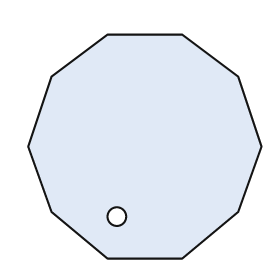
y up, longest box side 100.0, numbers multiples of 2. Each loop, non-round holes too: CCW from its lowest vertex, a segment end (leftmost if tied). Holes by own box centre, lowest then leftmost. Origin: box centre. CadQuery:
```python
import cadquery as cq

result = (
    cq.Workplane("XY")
    .moveTo(-16.0, -48.0)
    .lineTo(16.0, -48.0)
    .lineTo(40.0, -28.0)
    .lineTo(50.0, 0.0)
    .lineTo(40.0, 30.0)
    .lineTo(16.0, 48.0)
    .lineTo(-16.0, 48.0)
    .lineTo(-40.0, 30.0)
    .lineTo(-50.0, 0.0)
    .lineTo(-40.0, -28.0)
    .close()
    .moveTo(-12.0, -30.0)
    .circle(4.0)
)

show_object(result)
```